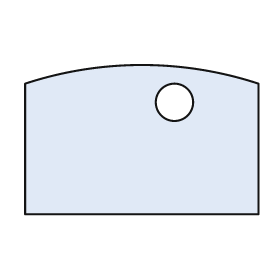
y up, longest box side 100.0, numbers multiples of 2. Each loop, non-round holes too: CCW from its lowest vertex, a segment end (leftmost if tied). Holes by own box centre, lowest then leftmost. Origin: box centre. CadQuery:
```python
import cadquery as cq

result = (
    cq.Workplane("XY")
    .moveTo(-50.0, -32.0)
    .lineTo(50.0, -32.0)
    .lineTo(50.0, 24.0)
    .threePointArc((0.0, 32.0), (-50.0, 24.0))
    .close()
    .moveTo(14.0, 16.0)
    .circle(8.0)
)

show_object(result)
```